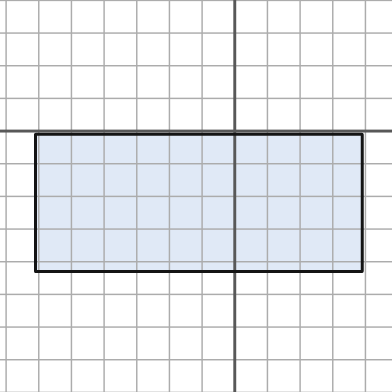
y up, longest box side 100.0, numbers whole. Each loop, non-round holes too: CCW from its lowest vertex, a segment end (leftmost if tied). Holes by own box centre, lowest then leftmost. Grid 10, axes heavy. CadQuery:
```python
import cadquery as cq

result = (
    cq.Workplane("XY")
    .moveTo(-61.0, -43.0)
    .lineTo(39.0, -43.0)
    .lineTo(39.0, -1.0)
    .lineTo(-61.0, -1.0)
    .close()
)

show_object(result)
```